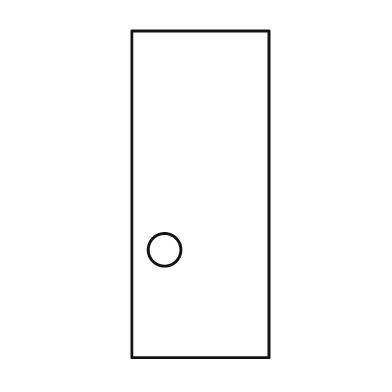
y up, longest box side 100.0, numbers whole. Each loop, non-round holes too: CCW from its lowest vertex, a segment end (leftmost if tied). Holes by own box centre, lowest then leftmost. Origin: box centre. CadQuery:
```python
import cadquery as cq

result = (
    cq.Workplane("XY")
    .moveTo(-21.0, -50.0)
    .lineTo(21.0, -50.0)
    .lineTo(21.0, 50.0)
    .lineTo(-21.0, 50.0)
    .close()
    .moveTo(-11.0, -17.0)
    .circle(5.0)
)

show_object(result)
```